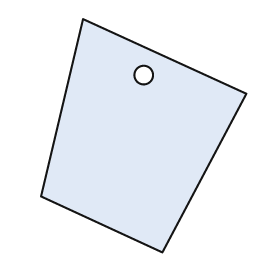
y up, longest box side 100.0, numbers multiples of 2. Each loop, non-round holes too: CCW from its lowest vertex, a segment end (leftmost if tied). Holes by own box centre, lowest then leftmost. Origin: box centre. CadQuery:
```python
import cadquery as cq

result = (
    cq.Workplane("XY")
    .moveTo(8.0, -50.0)
    .lineTo(44.0, 18.0)
    .lineTo(-26.0, 50.0)
    .lineTo(-44.0, -26.0)
    .close()
    .moveTo(0.0, 26.0)
    .circle(4.0)
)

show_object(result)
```